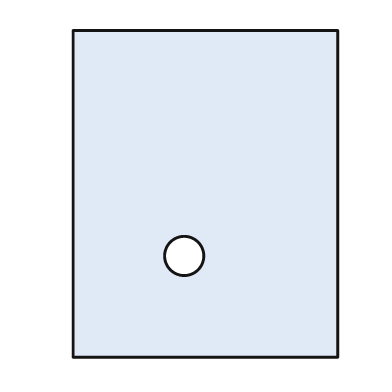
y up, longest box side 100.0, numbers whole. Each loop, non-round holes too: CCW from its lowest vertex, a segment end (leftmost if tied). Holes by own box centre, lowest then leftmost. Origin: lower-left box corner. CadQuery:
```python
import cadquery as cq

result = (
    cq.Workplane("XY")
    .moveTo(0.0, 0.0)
    .lineTo(81.0, 0.0)
    .lineTo(81.0, 100.0)
    .lineTo(0.0, 100.0)
    .close()
    .moveTo(34.0, 31.0)
    .circle(6.0)
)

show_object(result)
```